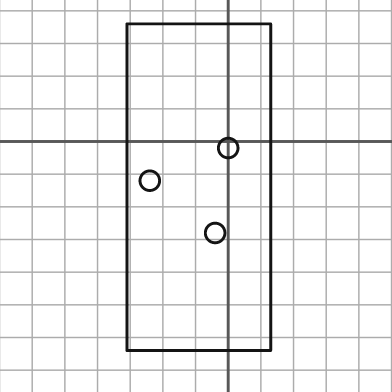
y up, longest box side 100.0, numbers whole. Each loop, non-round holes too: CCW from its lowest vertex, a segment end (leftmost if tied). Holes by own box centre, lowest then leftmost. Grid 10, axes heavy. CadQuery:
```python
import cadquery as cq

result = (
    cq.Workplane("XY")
    .moveTo(-31.0, -64.0)
    .lineTo(13.0, -64.0)
    .lineTo(13.0, 36.0)
    .lineTo(-31.0, 36.0)
    .close()
    .moveTo(-4.0, -28.0)
    .circle(3.0)
    .moveTo(-24.0, -12.0)
    .circle(3.0)
    .moveTo(0.0, -2.0)
    .circle(3.0)
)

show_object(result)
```